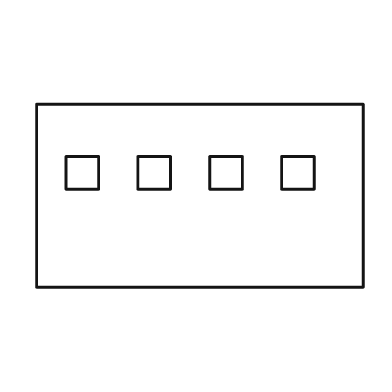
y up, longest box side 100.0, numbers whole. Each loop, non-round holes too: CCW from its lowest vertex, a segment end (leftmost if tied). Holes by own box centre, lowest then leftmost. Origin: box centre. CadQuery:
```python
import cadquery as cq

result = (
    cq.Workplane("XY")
    .moveTo(-50.0, -28.0)
    .lineTo(50.0, -28.0)
    .lineTo(50.0, 28.0)
    .lineTo(-50.0, 28.0)
    .close()
    .moveTo(-41.0, 2.0)
    .lineTo(-31.0, 2.0)
    .lineTo(-31.0, 12.0)
    .lineTo(-41.0, 12.0)
    .close()
    .moveTo(-19.0, 2.0)
    .lineTo(-9.0, 2.0)
    .lineTo(-9.0, 12.0)
    .lineTo(-19.0, 12.0)
    .close()
    .moveTo(3.0, 2.0)
    .lineTo(13.0, 2.0)
    .lineTo(13.0, 12.0)
    .lineTo(3.0, 12.0)
    .close()
    .moveTo(25.0, 2.0)
    .lineTo(35.0, 2.0)
    .lineTo(35.0, 12.0)
    .lineTo(25.0, 12.0)
    .close()
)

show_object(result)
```